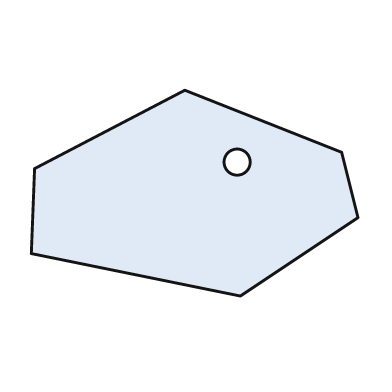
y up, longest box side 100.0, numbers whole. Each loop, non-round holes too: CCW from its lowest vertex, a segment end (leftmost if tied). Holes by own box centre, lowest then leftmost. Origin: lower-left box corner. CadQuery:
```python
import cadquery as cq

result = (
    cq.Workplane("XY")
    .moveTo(64.0, 0.0)
    .lineTo(100.0, 24.0)
    .lineTo(95.0, 44.0)
    .lineTo(47.0, 63.0)
    .lineTo(1.0, 39.0)
    .lineTo(0.0, 13.0)
    .close()
    .moveTo(63.0, 41.0)
    .circle(4.0)
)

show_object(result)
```